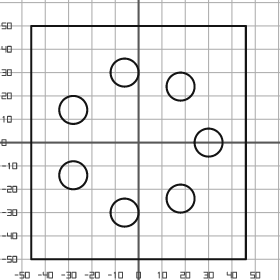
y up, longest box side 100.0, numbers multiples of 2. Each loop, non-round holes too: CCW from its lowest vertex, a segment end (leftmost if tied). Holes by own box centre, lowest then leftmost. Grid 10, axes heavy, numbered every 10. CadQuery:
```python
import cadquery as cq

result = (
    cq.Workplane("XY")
    .moveTo(-46.0, -50.0)
    .lineTo(46.0, -50.0)
    .lineTo(46.0, 50.0)
    .lineTo(-46.0, 50.0)
    .close()
    .moveTo(-6.0, -30.0)
    .circle(6.0)
    .moveTo(18.0, -24.0)
    .circle(6.0)
    .moveTo(-28.0, -14.0)
    .circle(6.0)
    .moveTo(30.0, 0.0)
    .circle(6.0)
    .moveTo(-28.0, 14.0)
    .circle(6.0)
    .moveTo(18.0, 24.0)
    .circle(6.0)
    .moveTo(-6.0, 30.0)
    .circle(6.0)
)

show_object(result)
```